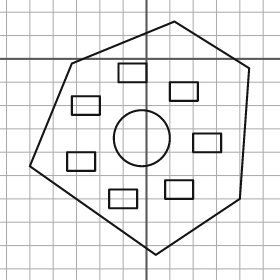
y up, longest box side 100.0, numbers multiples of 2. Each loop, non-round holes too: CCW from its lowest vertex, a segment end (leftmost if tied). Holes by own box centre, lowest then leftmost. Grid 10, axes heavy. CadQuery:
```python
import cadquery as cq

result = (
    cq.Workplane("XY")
    .moveTo(4.0, -84.0)
    .lineTo(40.0, -60.0)
    .lineTo(44.0, -4.0)
    .lineTo(12.0, 16.0)
    .lineTo(-32.0, -2.0)
    .lineTo(-50.0, -46.0)
    .close()
    .moveTo(-16.0, -64.0)
    .lineTo(-4.0, -64.0)
    .lineTo(-4.0, -56.0)
    .lineTo(-16.0, -56.0)
    .close()
    .moveTo(8.0, -60.0)
    .lineTo(20.0, -60.0)
    .lineTo(20.0, -52.0)
    .lineTo(8.0, -52.0)
    .close()
    .moveTo(-34.0, -48.0)
    .lineTo(-22.0, -48.0)
    .lineTo(-22.0, -40.0)
    .lineTo(-34.0, -40.0)
    .close()
    .moveTo(20.0, -40.0)
    .lineTo(32.0, -40.0)
    .lineTo(32.0, -32.0)
    .lineTo(20.0, -32.0)
    .close()
    .moveTo(-2.0, -34.0)
    .circle(12.0)
    .moveTo(-32.0, -24.0)
    .lineTo(-20.0, -24.0)
    .lineTo(-20.0, -16.0)
    .lineTo(-32.0, -16.0)
    .close()
    .moveTo(10.0, -18.0)
    .lineTo(22.0, -18.0)
    .lineTo(22.0, -10.0)
    .lineTo(10.0, -10.0)
    .close()
    .moveTo(-12.0, -10.0)
    .lineTo(0.0, -10.0)
    .lineTo(0.0, -2.0)
    .lineTo(-12.0, -2.0)
    .close()
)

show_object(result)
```